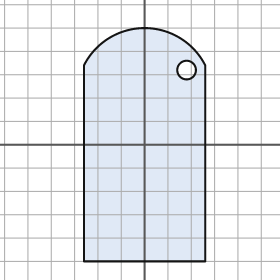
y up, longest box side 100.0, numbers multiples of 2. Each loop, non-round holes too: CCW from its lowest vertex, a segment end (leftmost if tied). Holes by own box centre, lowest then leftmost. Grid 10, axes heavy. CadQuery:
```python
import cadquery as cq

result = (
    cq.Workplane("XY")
    .moveTo(-26.0, -50.0)
    .lineTo(26.0, -50.0)
    .lineTo(26.0, 34.0)
    .threePointArc((0.0, 50.0), (-26.0, 34.0))
    .close()
    .moveTo(18.0, 32.0)
    .circle(4.0)
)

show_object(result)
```